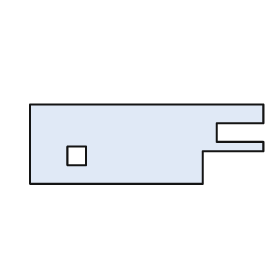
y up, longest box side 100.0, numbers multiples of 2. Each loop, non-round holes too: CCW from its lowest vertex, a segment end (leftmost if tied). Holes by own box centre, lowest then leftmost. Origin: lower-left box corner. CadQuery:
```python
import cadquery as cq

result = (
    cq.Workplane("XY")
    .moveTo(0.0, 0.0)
    .lineTo(74.0, 0.0)
    .lineTo(74.0, 14.0)
    .lineTo(100.0, 14.0)
    .lineTo(100.0, 18.0)
    .lineTo(80.0, 18.0)
    .lineTo(80.0, 26.0)
    .lineTo(100.0, 26.0)
    .lineTo(100.0, 34.0)
    .lineTo(0.0, 34.0)
    .close()
    .moveTo(16.0, 8.0)
    .lineTo(24.0, 8.0)
    .lineTo(24.0, 16.0)
    .lineTo(16.0, 16.0)
    .close()
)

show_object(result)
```